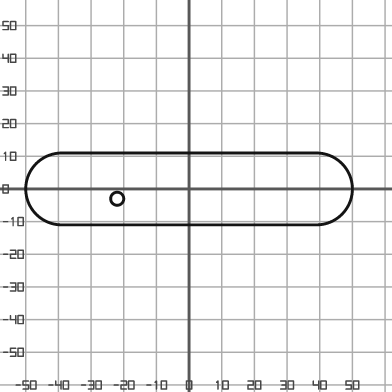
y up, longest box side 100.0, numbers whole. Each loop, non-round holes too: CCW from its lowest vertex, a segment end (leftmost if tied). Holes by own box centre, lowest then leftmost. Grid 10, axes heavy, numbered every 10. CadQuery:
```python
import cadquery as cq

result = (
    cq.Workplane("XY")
    .moveTo(-39.0, -11.0)
    .lineTo(39.0, -11.0)
    .threePointArc((50.0, 0.0), (39.0, 11.0))
    .lineTo(-39.0, 11.0)
    .threePointArc((-50.0, 0.0), (-39.0, -11.0))
    .close()
    .moveTo(-22.0, -3.0)
    .circle(2.0)
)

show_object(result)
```